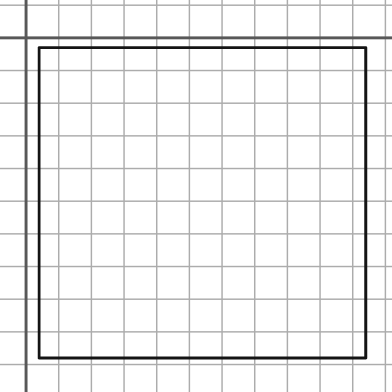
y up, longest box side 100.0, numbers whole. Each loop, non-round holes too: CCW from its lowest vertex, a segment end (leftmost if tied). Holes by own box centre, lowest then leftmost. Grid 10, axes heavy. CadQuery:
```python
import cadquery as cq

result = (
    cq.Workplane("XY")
    .moveTo(4.0, -98.0)
    .lineTo(104.0, -98.0)
    .lineTo(104.0, -3.0)
    .lineTo(4.0, -3.0)
    .close()
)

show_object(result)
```